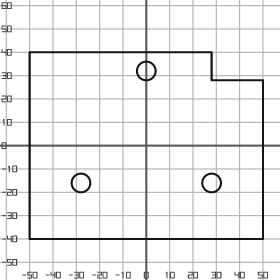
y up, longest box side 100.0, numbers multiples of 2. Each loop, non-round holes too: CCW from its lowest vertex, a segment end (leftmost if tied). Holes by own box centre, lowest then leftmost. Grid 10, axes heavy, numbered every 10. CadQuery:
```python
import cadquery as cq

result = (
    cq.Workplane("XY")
    .moveTo(-50.0, -40.0)
    .lineTo(50.0, -40.0)
    .lineTo(50.0, 28.0)
    .lineTo(28.0, 28.0)
    .lineTo(28.0, 40.0)
    .lineTo(-50.0, 40.0)
    .close()
    .moveTo(-28.0, -16.0)
    .circle(4.0)
    .moveTo(28.0, -16.0)
    .circle(4.0)
    .moveTo(0.0, 32.0)
    .circle(4.0)
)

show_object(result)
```